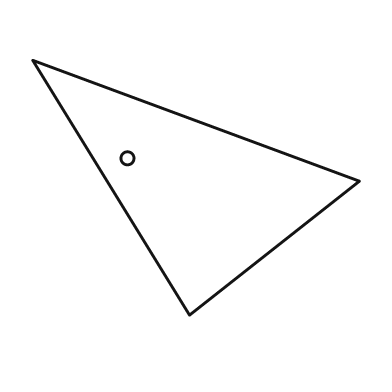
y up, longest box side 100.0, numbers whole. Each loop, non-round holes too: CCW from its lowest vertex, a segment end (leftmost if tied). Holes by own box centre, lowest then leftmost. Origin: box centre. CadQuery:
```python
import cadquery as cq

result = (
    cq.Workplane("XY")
    .moveTo(-2.0, -39.0)
    .lineTo(50.0, 2.0)
    .lineTo(-50.0, 39.0)
    .close()
    .moveTo(-21.0, 9.0)
    .circle(2.0)
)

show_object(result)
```